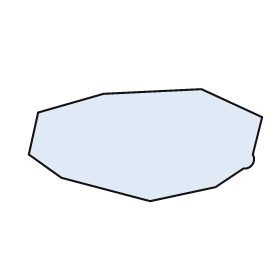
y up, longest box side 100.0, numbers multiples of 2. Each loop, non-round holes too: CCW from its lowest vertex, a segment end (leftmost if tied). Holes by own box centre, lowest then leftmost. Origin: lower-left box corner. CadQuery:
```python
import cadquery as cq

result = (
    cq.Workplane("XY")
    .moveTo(52.0, 0.0)
    .lineTo(80.0, 6.0)
    .lineTo(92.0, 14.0)
    .threePointArc((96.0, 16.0), (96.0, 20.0))
    .lineTo(100.0, 36.0)
    .lineTo(74.0, 48.0)
    .lineTo(32.0, 46.0)
    .lineTo(4.0, 38.0)
    .lineTo(0.0, 20.0)
    .lineTo(14.0, 10.0)
    .close()
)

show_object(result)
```